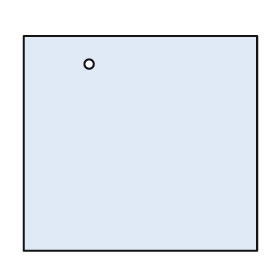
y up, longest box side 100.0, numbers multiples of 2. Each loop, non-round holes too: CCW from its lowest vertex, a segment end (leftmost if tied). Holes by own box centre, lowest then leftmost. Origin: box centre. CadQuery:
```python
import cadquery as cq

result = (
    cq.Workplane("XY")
    .moveTo(-50.0, -46.0)
    .lineTo(50.0, -46.0)
    .lineTo(50.0, 46.0)
    .lineTo(-50.0, 46.0)
    .close()
    .moveTo(-22.0, 34.0)
    .circle(2.0)
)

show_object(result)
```